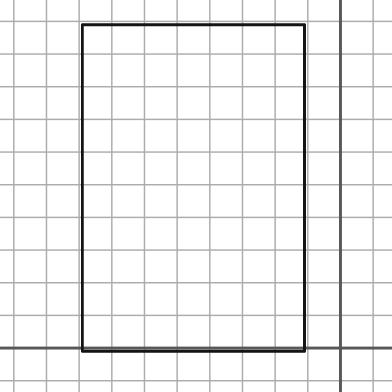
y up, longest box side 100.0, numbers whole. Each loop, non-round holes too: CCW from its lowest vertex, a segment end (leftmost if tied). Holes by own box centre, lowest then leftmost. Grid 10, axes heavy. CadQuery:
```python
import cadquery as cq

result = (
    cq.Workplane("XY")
    .moveTo(-79.0, -1.0)
    .lineTo(-11.0, -1.0)
    .lineTo(-11.0, 99.0)
    .lineTo(-79.0, 99.0)
    .close()
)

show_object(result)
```